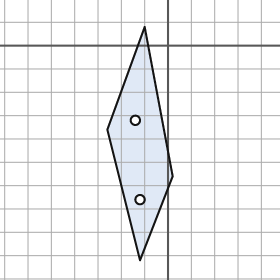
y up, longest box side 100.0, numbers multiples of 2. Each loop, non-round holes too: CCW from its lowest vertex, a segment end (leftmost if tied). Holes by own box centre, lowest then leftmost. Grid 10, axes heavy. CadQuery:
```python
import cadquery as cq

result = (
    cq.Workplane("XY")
    .moveTo(-12.0, -92.0)
    .lineTo(2.0, -56.0)
    .lineTo(-10.0, 8.0)
    .lineTo(-26.0, -36.0)
    .close()
    .moveTo(-12.0, -66.0)
    .circle(2.0)
    .moveTo(-14.0, -32.0)
    .circle(2.0)
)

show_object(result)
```